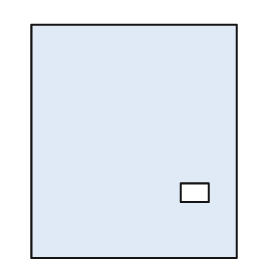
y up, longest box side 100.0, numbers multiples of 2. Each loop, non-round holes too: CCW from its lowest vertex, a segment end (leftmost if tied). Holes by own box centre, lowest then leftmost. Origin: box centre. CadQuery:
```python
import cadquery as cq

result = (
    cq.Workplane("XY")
    .moveTo(-44.0, -50.0)
    .lineTo(44.0, -50.0)
    .lineTo(44.0, 50.0)
    .lineTo(-44.0, 50.0)
    .close()
    .moveTo(20.0, -26.0)
    .lineTo(32.0, -26.0)
    .lineTo(32.0, -18.0)
    .lineTo(20.0, -18.0)
    .close()
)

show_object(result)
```